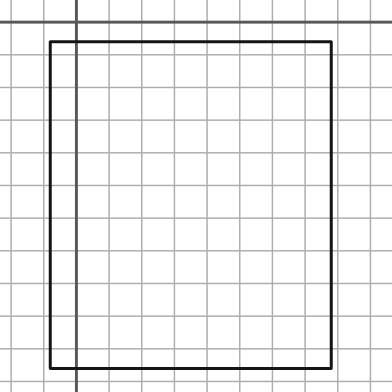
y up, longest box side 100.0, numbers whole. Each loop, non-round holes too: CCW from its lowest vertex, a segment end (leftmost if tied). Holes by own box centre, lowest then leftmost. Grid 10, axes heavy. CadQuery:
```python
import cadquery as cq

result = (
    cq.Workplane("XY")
    .moveTo(-8.0, -106.0)
    .lineTo(78.0, -106.0)
    .lineTo(78.0, -6.0)
    .lineTo(-8.0, -6.0)
    .close()
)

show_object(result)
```